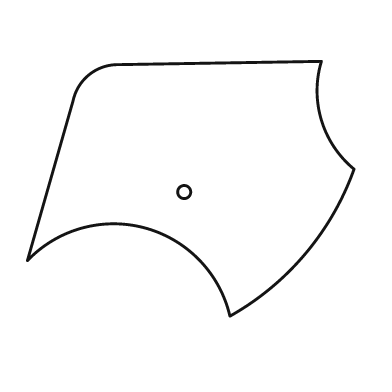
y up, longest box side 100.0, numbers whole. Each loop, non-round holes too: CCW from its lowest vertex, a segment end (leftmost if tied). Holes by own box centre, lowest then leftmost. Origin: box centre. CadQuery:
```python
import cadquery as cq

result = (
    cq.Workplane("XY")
    .moveTo(12.0, -39.0)
    .threePointArc((35.0, -20.0), (50.0, 6.0))
    .threePointArc((40.0, 21.0), (40.0, 39.0))
    .lineTo(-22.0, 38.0)
    .threePointArc((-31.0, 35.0), (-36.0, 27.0))
    .lineTo(-50.0, -22.0)
    .threePointArc((-14.0, -12.0), (12.0, -39.0))
    .close()
    .moveTo(-2.0, -1.0)
    .circle(2.0)
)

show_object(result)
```